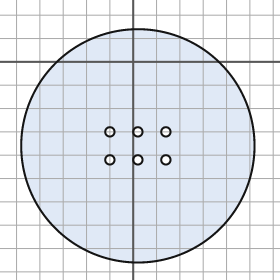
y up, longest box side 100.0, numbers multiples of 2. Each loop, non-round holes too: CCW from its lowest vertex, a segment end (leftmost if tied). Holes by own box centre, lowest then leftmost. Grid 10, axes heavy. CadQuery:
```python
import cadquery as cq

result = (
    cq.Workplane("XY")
    .moveTo(2.0, -36.0)
    .circle(50.0)
    .moveTo(-10.0, -42.0)
    .circle(2.0)
    .moveTo(2.0, -42.0)
    .circle(2.0)
    .moveTo(14.0, -42.0)
    .circle(2.0)
    .moveTo(-10.0, -30.0)
    .circle(2.0)
    .moveTo(2.0, -30.0)
    .circle(2.0)
    .moveTo(14.0, -30.0)
    .circle(2.0)
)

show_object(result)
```